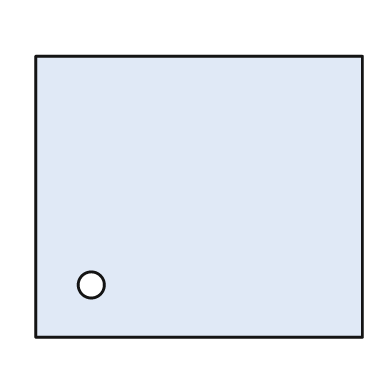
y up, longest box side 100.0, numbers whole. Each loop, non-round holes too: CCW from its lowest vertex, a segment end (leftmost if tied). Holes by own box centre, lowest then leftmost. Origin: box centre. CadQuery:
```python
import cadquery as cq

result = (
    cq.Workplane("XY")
    .moveTo(-50.0, -43.0)
    .lineTo(50.0, -43.0)
    .lineTo(50.0, 43.0)
    .lineTo(-50.0, 43.0)
    .close()
    .moveTo(-33.0, -27.0)
    .circle(4.0)
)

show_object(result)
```